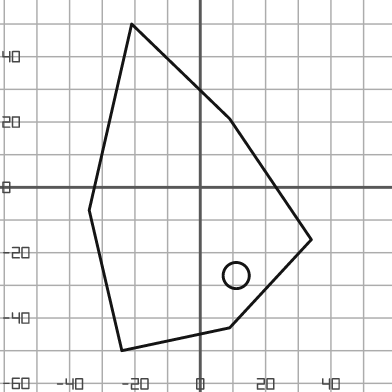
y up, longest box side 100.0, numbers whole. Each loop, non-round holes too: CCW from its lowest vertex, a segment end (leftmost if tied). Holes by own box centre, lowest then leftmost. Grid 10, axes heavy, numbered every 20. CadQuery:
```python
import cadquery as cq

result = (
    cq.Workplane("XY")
    .moveTo(-24.0, -50.0)
    .lineTo(9.0, -43.0)
    .lineTo(34.0, -16.0)
    .lineTo(9.0, 21.0)
    .lineTo(-21.0, 50.0)
    .lineTo(-34.0, -7.0)
    .close()
    .moveTo(11.0, -27.0)
    .circle(4.0)
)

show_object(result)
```